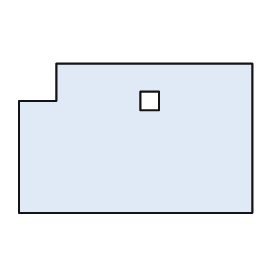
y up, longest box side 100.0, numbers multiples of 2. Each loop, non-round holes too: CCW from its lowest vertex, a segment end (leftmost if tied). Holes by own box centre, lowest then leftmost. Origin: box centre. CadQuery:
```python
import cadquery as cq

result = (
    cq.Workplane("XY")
    .moveTo(-50.0, -32.0)
    .lineTo(50.0, -32.0)
    .lineTo(50.0, 32.0)
    .lineTo(-34.0, 32.0)
    .lineTo(-34.0, 16.0)
    .lineTo(-50.0, 16.0)
    .close()
    .moveTo(2.0, 12.0)
    .lineTo(10.0, 12.0)
    .lineTo(10.0, 20.0)
    .lineTo(2.0, 20.0)
    .close()
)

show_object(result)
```